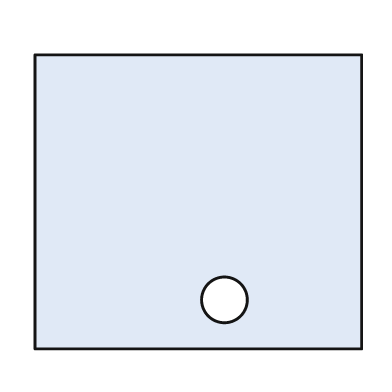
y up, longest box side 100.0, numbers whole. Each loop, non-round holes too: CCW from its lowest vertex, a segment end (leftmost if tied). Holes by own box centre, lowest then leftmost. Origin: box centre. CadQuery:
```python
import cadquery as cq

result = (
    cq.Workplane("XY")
    .moveTo(-50.0, -45.0)
    .lineTo(50.0, -45.0)
    .lineTo(50.0, 45.0)
    .lineTo(-50.0, 45.0)
    .close()
    .moveTo(8.0, -30.0)
    .circle(7.0)
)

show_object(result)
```